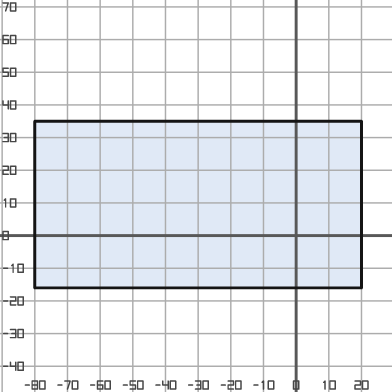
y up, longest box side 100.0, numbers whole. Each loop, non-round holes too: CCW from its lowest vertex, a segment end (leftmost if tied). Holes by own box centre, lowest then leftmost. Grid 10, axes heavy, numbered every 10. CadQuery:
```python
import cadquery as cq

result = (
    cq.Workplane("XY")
    .moveTo(-80.0, -16.0)
    .lineTo(20.0, -16.0)
    .lineTo(20.0, 35.0)
    .lineTo(-80.0, 35.0)
    .close()
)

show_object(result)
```